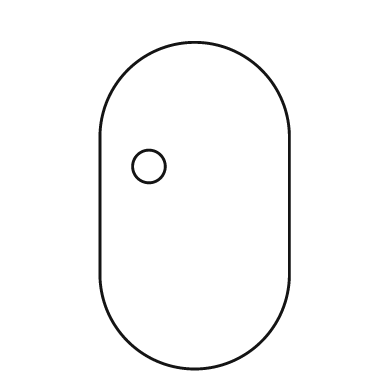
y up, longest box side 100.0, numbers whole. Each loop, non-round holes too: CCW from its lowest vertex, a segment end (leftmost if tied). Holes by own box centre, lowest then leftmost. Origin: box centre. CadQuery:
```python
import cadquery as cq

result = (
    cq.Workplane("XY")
    .moveTo(-29.0, -21.0)
    .threePointArc((0.0, -50.0), (29.0, -21.0))
    .lineTo(29.0, 21.0)
    .threePointArc((0.0, 50.0), (-29.0, 21.0))
    .close()
    .moveTo(-14.0, 12.0)
    .circle(5.0)
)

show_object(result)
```